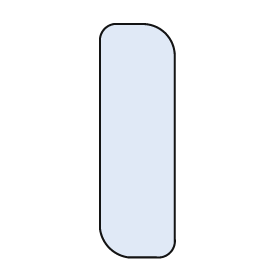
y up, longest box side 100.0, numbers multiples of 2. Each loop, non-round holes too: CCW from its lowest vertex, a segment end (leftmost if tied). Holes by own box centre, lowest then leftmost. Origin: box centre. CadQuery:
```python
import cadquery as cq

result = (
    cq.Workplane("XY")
    .moveTo(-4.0, -50.0)
    .lineTo(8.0, -50.0)
    .threePointArc((14.0, -48.0), (16.0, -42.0))
    .lineTo(16.0, 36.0)
    .threePointArc((12.0, 46.0), (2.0, 50.0))
    .lineTo(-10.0, 50.0)
    .threePointArc((-14.0, 48.0), (-16.0, 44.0))
    .lineTo(-16.0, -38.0)
    .threePointArc((-12.0, -46.0), (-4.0, -50.0))
    .close()
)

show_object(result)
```